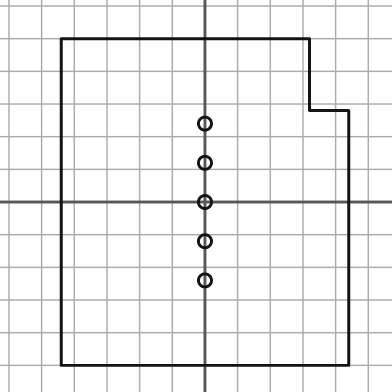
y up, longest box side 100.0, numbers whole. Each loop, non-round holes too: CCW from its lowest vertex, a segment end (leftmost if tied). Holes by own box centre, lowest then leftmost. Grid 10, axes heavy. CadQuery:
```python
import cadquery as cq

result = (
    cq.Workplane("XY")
    .moveTo(-44.0, -50.0)
    .lineTo(44.0, -50.0)
    .lineTo(44.0, 28.0)
    .lineTo(32.0, 28.0)
    .lineTo(32.0, 50.0)
    .lineTo(-44.0, 50.0)
    .close()
    .moveTo(0.0, -24.0)
    .circle(2.0)
    .moveTo(0.0, -12.0)
    .circle(2.0)
    .moveTo(0.0, 0.0)
    .circle(2.0)
    .moveTo(0.0, 12.0)
    .circle(2.0)
    .moveTo(0.0, 24.0)
    .circle(2.0)
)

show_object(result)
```